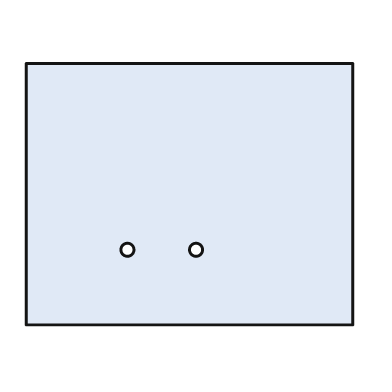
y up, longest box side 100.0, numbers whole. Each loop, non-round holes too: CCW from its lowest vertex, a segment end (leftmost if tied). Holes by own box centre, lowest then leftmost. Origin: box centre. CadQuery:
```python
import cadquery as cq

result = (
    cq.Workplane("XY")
    .moveTo(-50.0, -40.0)
    .lineTo(50.0, -40.0)
    .lineTo(50.0, 40.0)
    .lineTo(-50.0, 40.0)
    .close()
    .moveTo(-19.0, -17.0)
    .circle(2.0)
    .moveTo(2.0, -17.0)
    .circle(2.0)
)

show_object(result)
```